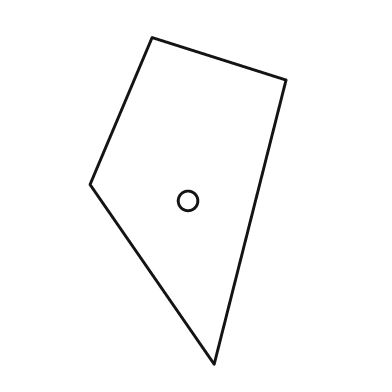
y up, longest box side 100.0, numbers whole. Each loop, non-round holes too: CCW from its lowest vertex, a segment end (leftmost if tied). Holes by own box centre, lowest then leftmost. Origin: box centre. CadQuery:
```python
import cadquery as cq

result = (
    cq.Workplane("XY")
    .moveTo(8.0, -50.0)
    .lineTo(30.0, 37.0)
    .lineTo(-11.0, 50.0)
    .lineTo(-30.0, 5.0)
    .close()
    .moveTo(0.0, 0.0)
    .circle(3.0)
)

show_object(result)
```